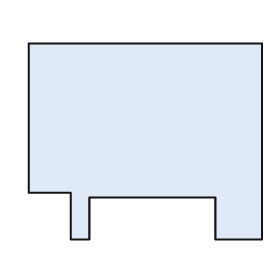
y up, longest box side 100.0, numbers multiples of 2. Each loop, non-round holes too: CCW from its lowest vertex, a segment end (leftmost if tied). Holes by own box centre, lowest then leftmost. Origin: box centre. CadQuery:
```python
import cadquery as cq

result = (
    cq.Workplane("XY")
    .moveTo(-32.0, -42.0)
    .lineTo(-24.0, -42.0)
    .lineTo(-24.0, -24.0)
    .lineTo(30.0, -24.0)
    .lineTo(30.0, -42.0)
    .lineTo(50.0, -42.0)
    .lineTo(50.0, 42.0)
    .lineTo(-50.0, 42.0)
    .lineTo(-50.0, -22.0)
    .lineTo(-32.0, -22.0)
    .close()
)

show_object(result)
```